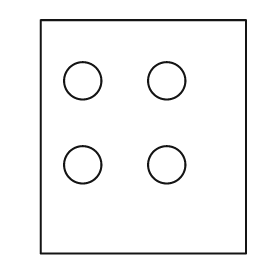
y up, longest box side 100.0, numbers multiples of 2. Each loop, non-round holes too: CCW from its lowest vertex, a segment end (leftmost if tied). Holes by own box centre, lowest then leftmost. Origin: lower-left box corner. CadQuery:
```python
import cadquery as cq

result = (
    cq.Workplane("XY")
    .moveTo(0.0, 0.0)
    .lineTo(88.0, 0.0)
    .lineTo(88.0, 100.0)
    .lineTo(0.0, 100.0)
    .close()
    .moveTo(18.0, 38.0)
    .circle(8.0)
    .moveTo(54.0, 38.0)
    .circle(8.0)
    .moveTo(18.0, 74.0)
    .circle(8.0)
    .moveTo(54.0, 74.0)
    .circle(8.0)
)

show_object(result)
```